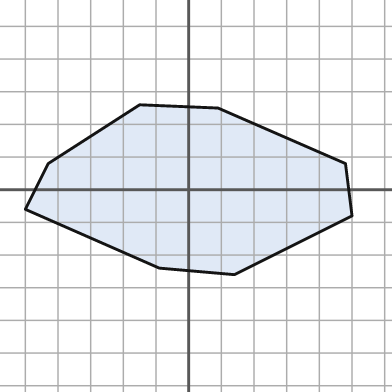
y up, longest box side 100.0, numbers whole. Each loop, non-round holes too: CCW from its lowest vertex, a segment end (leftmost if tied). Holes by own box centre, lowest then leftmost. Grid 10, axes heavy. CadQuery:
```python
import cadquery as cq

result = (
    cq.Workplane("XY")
    .moveTo(14.0, -26.0)
    .lineTo(50.0, -8.0)
    .lineTo(48.0, 8.0)
    .lineTo(9.0, 25.0)
    .lineTo(-15.0, 26.0)
    .lineTo(-43.0, 8.0)
    .lineTo(-50.0, -6.0)
    .lineTo(-9.0, -24.0)
    .close()
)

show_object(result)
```